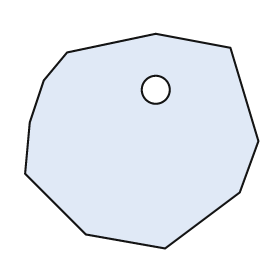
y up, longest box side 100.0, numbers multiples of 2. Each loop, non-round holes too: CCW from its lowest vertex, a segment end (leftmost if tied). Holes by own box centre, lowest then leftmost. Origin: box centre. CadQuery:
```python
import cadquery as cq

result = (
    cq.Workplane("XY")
    .moveTo(10.0, -46.0)
    .lineTo(42.0, -22.0)
    .lineTo(50.0, 0.0)
    .lineTo(38.0, 40.0)
    .lineTo(6.0, 46.0)
    .lineTo(-32.0, 38.0)
    .lineTo(-42.0, 26.0)
    .lineTo(-48.0, 8.0)
    .lineTo(-50.0, -14.0)
    .lineTo(-24.0, -40.0)
    .close()
    .moveTo(6.0, 22.0)
    .circle(6.0)
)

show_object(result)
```